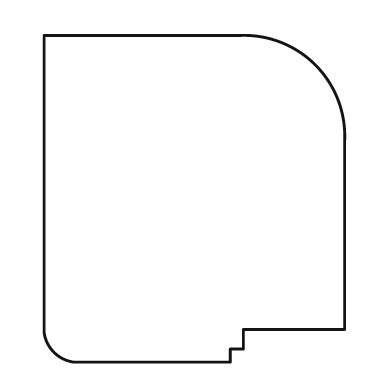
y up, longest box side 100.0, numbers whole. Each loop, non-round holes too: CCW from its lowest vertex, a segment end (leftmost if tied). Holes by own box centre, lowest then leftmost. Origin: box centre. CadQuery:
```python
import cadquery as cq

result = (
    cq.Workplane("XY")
    .moveTo(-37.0, -50.0)
    .lineTo(11.0, -50.0)
    .lineTo(11.0, -46.0)
    .lineTo(15.0, -46.0)
    .lineTo(15.0, -40.0)
    .lineTo(46.0, -40.0)
    .lineTo(46.0, 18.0)
    .threePointArc((37.0, 41.0), (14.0, 50.0))
    .lineTo(-46.0, 50.0)
    .lineTo(-46.0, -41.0)
    .threePointArc((-43.0, -47.0), (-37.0, -50.0))
    .close()
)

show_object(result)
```